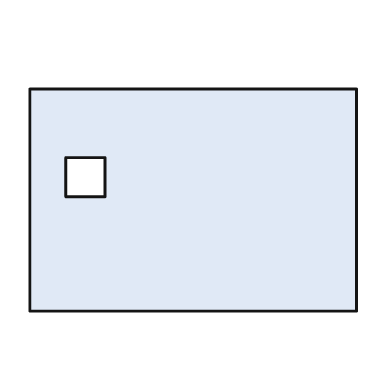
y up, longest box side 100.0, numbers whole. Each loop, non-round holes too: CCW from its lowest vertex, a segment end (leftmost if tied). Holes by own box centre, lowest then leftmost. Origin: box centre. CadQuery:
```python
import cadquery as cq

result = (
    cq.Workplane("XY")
    .moveTo(-50.0, -34.0)
    .lineTo(50.0, -34.0)
    .lineTo(50.0, 34.0)
    .lineTo(-50.0, 34.0)
    .close()
    .moveTo(-39.0, 1.0)
    .lineTo(-27.0, 1.0)
    .lineTo(-27.0, 13.0)
    .lineTo(-39.0, 13.0)
    .close()
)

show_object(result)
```